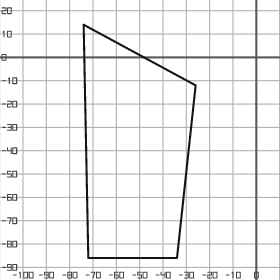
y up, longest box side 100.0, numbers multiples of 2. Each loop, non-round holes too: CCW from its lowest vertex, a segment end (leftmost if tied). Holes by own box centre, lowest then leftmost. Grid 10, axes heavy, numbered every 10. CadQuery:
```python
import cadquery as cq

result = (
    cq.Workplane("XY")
    .moveTo(-72.0, -86.0)
    .lineTo(-34.0, -86.0)
    .lineTo(-26.0, -12.0)
    .lineTo(-74.0, 14.0)
    .close()
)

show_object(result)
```